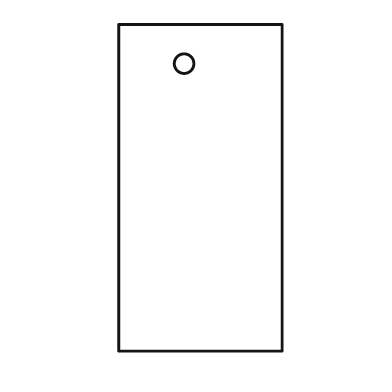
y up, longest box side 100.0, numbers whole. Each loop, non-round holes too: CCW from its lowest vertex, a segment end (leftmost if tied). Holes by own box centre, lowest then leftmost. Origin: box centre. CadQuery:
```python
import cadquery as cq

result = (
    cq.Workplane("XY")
    .moveTo(-25.0, -50.0)
    .lineTo(25.0, -50.0)
    .lineTo(25.0, 50.0)
    .lineTo(-25.0, 50.0)
    .close()
    .moveTo(-5.0, 38.0)
    .circle(3.0)
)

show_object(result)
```